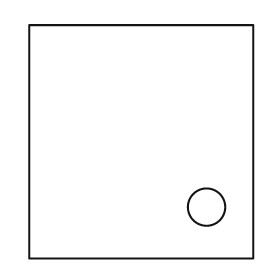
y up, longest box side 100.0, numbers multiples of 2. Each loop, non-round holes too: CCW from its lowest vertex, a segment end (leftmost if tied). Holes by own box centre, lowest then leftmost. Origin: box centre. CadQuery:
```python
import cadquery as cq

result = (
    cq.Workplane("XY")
    .moveTo(-48.0, -50.0)
    .lineTo(48.0, -50.0)
    .lineTo(48.0, 50.0)
    .lineTo(-48.0, 50.0)
    .close()
    .moveTo(28.0, -28.0)
    .circle(8.0)
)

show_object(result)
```